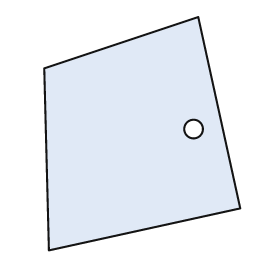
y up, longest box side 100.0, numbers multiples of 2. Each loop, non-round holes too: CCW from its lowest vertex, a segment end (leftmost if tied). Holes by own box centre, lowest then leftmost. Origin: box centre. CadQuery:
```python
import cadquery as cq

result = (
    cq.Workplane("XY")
    .moveTo(-40.0, -50.0)
    .lineTo(42.0, -32.0)
    .lineTo(24.0, 50.0)
    .lineTo(-42.0, 28.0)
    .close()
    .moveTo(22.0, 2.0)
    .circle(4.0)
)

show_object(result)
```